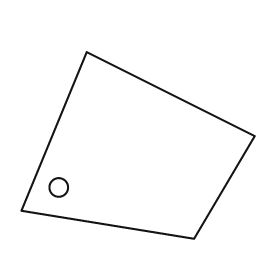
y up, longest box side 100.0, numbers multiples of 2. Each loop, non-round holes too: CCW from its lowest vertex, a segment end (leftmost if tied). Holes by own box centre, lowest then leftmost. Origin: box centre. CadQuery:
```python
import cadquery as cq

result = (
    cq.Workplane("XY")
    .moveTo(24.0, -40.0)
    .lineTo(50.0, 4.0)
    .lineTo(-22.0, 40.0)
    .lineTo(-50.0, -28.0)
    .close()
    .moveTo(-34.0, -18.0)
    .circle(4.0)
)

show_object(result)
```